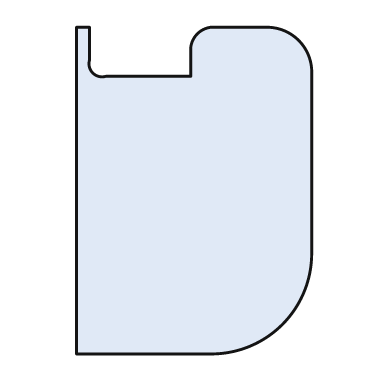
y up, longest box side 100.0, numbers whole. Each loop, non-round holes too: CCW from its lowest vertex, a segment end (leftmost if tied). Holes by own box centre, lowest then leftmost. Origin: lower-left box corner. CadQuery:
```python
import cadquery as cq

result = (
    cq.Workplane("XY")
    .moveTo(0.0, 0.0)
    .lineTo(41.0, 0.0)
    .threePointArc((63.0, 9.0), (72.0, 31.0))
    .lineTo(72.0, 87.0)
    .threePointArc((68.0, 96.0), (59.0, 100.0))
    .lineTo(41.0, 100.0)
    .threePointArc((37.0, 98.0), (35.0, 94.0))
    .lineTo(35.0, 85.0)
    .lineTo(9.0, 85.0)
    .threePointArc((5.0, 86.0), (4.0, 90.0))
    .lineTo(4.0, 100.0)
    .lineTo(0.0, 100.0)
    .close()
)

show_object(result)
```